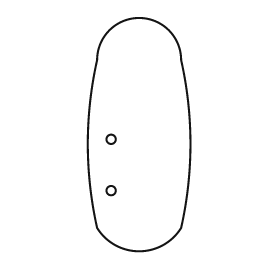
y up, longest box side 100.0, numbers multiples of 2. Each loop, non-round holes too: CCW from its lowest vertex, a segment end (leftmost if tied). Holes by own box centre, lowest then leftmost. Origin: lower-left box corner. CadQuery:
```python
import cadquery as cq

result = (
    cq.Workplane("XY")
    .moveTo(4.0, 10.0)
    .threePointArc((22.0, 0.0), (40.0, 10.0))
    .threePointArc((44.0, 46.0), (40.0, 82.0))
    .threePointArc((22.0, 100.0), (4.0, 82.0))
    .threePointArc((0.0, 46.0), (4.0, 10.0))
    .close()
    .moveTo(10.0, 26.0)
    .circle(2.0)
    .moveTo(10.0, 48.0)
    .circle(2.0)
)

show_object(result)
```